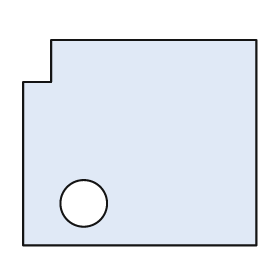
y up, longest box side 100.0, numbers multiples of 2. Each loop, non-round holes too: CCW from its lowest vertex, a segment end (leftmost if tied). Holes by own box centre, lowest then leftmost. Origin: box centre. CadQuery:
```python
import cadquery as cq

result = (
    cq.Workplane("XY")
    .moveTo(-50.0, -44.0)
    .lineTo(50.0, -44.0)
    .lineTo(50.0, 44.0)
    .lineTo(-38.0, 44.0)
    .lineTo(-38.0, 26.0)
    .lineTo(-50.0, 26.0)
    .close()
    .moveTo(-24.0, -26.0)
    .circle(10.0)
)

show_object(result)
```